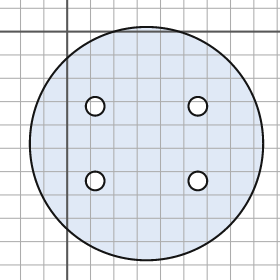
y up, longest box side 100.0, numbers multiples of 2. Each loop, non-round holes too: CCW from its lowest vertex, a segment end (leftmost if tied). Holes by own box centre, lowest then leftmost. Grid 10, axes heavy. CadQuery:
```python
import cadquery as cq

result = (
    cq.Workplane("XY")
    .moveTo(34.0, -48.0)
    .circle(50.0)
    .moveTo(12.0, -64.0)
    .circle(4.0)
    .moveTo(56.0, -64.0)
    .circle(4.0)
    .moveTo(12.0, -32.0)
    .circle(4.0)
    .moveTo(56.0, -32.0)
    .circle(4.0)
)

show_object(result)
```